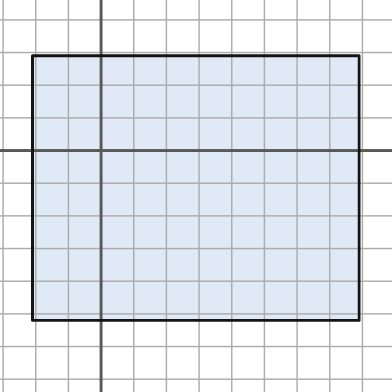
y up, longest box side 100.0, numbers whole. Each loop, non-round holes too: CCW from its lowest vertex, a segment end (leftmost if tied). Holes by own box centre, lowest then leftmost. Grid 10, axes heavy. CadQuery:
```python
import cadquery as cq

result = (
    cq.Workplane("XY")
    .moveTo(-21.0, -52.0)
    .lineTo(79.0, -52.0)
    .lineTo(79.0, 29.0)
    .lineTo(-21.0, 29.0)
    .close()
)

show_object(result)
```